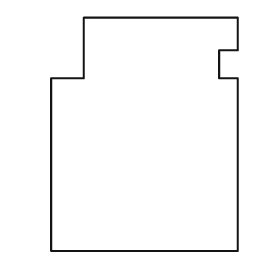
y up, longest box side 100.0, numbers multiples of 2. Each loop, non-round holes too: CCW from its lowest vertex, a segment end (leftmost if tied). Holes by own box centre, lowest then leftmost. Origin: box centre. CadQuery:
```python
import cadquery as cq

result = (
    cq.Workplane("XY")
    .moveTo(-40.0, -50.0)
    .lineTo(40.0, -50.0)
    .lineTo(40.0, 24.0)
    .lineTo(32.0, 24.0)
    .lineTo(32.0, 36.0)
    .lineTo(40.0, 36.0)
    .lineTo(40.0, 50.0)
    .lineTo(-26.0, 50.0)
    .lineTo(-26.0, 24.0)
    .lineTo(-40.0, 24.0)
    .close()
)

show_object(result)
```